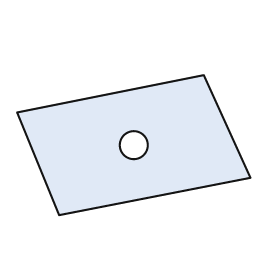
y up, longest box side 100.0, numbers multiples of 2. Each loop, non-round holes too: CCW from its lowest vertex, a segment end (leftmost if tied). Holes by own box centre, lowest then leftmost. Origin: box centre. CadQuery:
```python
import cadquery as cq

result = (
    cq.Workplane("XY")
    .moveTo(-32.0, -30.0)
    .lineTo(50.0, -14.0)
    .lineTo(30.0, 30.0)
    .lineTo(-50.0, 14.0)
    .close()
    .moveTo(0.0, 0.0)
    .circle(6.0)
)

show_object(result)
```